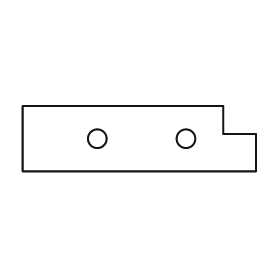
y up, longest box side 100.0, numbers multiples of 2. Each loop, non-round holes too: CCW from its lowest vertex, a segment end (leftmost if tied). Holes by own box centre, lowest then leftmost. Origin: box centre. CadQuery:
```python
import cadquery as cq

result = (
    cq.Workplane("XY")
    .moveTo(-50.0, -14.0)
    .lineTo(50.0, -14.0)
    .lineTo(50.0, 2.0)
    .lineTo(36.0, 2.0)
    .lineTo(36.0, 14.0)
    .lineTo(-50.0, 14.0)
    .close()
    .moveTo(-18.0, 0.0)
    .circle(4.0)
    .moveTo(20.0, 0.0)
    .circle(4.0)
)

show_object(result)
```